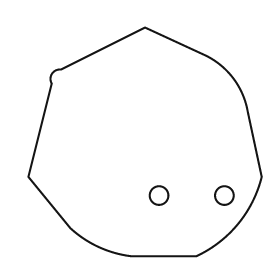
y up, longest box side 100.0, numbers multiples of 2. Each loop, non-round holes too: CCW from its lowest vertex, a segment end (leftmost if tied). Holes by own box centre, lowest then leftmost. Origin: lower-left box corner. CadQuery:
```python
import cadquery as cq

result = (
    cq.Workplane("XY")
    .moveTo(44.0, 0.0)
    .lineTo(72.0, 0.0)
    .threePointArc((90.0, 14.0), (100.0, 34.0))
    .lineTo(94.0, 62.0)
    .threePointArc((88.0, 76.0), (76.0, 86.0))
    .lineTo(50.0, 98.0)
    .lineTo(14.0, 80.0)
    .threePointArc((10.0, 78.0), (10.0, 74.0))
    .lineTo(0.0, 34.0)
    .lineTo(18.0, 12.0)
    .threePointArc((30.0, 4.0), (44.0, 0.0))
    .close()
    .moveTo(56.0, 26.0)
    .circle(4.0)
    .moveTo(84.0, 26.0)
    .circle(4.0)
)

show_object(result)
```